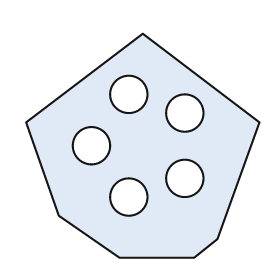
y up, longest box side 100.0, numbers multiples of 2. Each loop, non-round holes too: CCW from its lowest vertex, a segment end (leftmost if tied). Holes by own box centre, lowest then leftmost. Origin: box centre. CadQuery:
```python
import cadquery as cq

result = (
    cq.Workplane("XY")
    .moveTo(-10.0, -48.0)
    .lineTo(22.0, -48.0)
    .lineTo(32.0, -40.0)
    .lineTo(50.0, 10.0)
    .lineTo(0.0, 48.0)
    .lineTo(-50.0, 10.0)
    .lineTo(-36.0, -30.0)
    .close()
    .moveTo(-6.0, -22.0)
    .circle(8.0)
    .moveTo(18.0, -14.0)
    .circle(8.0)
    .moveTo(-22.0, 0.0)
    .circle(8.0)
    .moveTo(18.0, 14.0)
    .circle(8.0)
    .moveTo(-6.0, 22.0)
    .circle(8.0)
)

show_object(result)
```